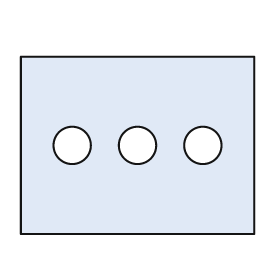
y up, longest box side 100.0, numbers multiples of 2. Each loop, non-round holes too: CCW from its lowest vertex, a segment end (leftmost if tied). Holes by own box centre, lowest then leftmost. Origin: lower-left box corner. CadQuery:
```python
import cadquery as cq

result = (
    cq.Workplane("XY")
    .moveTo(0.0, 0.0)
    .lineTo(100.0, 0.0)
    .lineTo(100.0, 76.0)
    .lineTo(0.0, 76.0)
    .close()
    .moveTo(22.0, 38.0)
    .circle(8.0)
    .moveTo(50.0, 38.0)
    .circle(8.0)
    .moveTo(78.0, 38.0)
    .circle(8.0)
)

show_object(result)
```